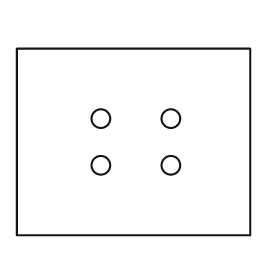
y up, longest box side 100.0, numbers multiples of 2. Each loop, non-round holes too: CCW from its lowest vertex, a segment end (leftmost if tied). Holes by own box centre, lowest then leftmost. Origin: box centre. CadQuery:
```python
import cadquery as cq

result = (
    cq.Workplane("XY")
    .moveTo(-50.0, -40.0)
    .lineTo(50.0, -40.0)
    .lineTo(50.0, 40.0)
    .lineTo(-50.0, 40.0)
    .close()
    .moveTo(-14.0, -10.0)
    .circle(4.0)
    .moveTo(16.0, -10.0)
    .circle(4.0)
    .moveTo(-14.0, 10.0)
    .circle(4.0)
    .moveTo(16.0, 10.0)
    .circle(4.0)
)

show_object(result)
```